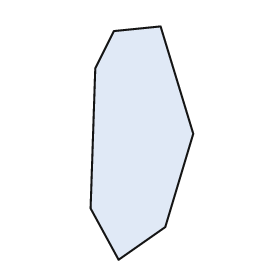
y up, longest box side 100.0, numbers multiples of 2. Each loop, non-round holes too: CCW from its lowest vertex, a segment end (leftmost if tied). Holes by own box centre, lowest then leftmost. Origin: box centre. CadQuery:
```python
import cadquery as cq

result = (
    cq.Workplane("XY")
    .moveTo(-10.0, -50.0)
    .lineTo(10.0, -36.0)
    .lineTo(22.0, 4.0)
    .lineTo(8.0, 50.0)
    .lineTo(-12.0, 48.0)
    .lineTo(-20.0, 32.0)
    .lineTo(-22.0, -28.0)
    .close()
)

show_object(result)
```